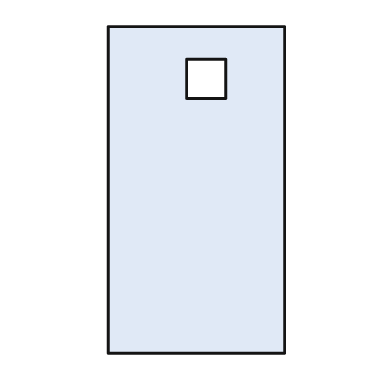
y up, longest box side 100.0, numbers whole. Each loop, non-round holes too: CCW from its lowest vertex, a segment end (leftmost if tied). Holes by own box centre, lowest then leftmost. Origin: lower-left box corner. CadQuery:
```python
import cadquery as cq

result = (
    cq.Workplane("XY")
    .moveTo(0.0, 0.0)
    .lineTo(54.0, 0.0)
    .lineTo(54.0, 100.0)
    .lineTo(0.0, 100.0)
    .close()
    .moveTo(24.0, 78.0)
    .lineTo(36.0, 78.0)
    .lineTo(36.0, 90.0)
    .lineTo(24.0, 90.0)
    .close()
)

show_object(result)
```